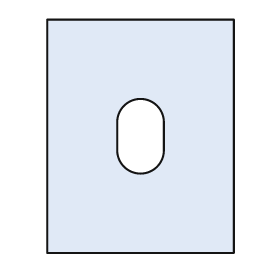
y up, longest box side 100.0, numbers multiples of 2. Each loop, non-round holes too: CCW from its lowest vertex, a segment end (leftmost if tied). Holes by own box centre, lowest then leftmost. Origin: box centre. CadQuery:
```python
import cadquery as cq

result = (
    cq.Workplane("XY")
    .moveTo(-40.0, -50.0)
    .lineTo(40.0, -50.0)
    .lineTo(40.0, 50.0)
    .lineTo(-40.0, 50.0)
    .close()
    .moveTo(-10.0, -6.0)
    .threePointArc((0.0, -16.0), (10.0, -6.0))
    .lineTo(10.0, 6.0)
    .threePointArc((0.0, 16.0), (-10.0, 6.0))
    .close()
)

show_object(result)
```